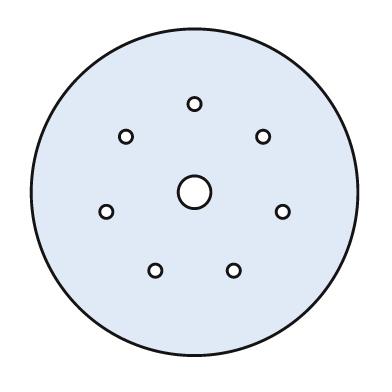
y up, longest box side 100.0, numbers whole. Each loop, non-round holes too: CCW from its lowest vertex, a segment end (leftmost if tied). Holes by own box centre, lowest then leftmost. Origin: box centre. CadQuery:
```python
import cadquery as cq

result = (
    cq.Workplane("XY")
    .moveTo(0.0, 0.0)
    .circle(50.0)
    .moveTo(-12.0, -24.0)
    .circle(2.0)
    .moveTo(12.0, -24.0)
    .circle(2.0)
    .moveTo(-27.0, -6.0)
    .circle(2.0)
    .moveTo(27.0, -6.0)
    .circle(2.0)
    .moveTo(0.0, 0.0)
    .circle(5.0)
    .moveTo(-21.0, 17.0)
    .circle(2.0)
    .moveTo(21.0, 17.0)
    .circle(2.0)
    .moveTo(0.0, 27.0)
    .circle(2.0)
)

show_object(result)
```